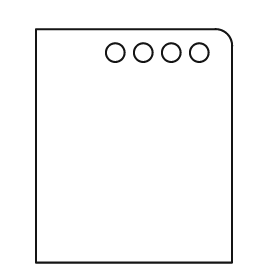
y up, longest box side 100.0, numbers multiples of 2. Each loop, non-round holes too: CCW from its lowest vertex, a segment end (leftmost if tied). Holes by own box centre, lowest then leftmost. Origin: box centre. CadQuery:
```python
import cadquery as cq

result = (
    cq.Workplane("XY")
    .moveTo(-42.0, -50.0)
    .lineTo(42.0, -50.0)
    .lineTo(42.0, 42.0)
    .threePointArc((40.0, 48.0), (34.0, 50.0))
    .lineTo(-42.0, 50.0)
    .close()
    .moveTo(-8.0, 40.0)
    .circle(4.0)
    .moveTo(4.0, 40.0)
    .circle(4.0)
    .moveTo(16.0, 40.0)
    .circle(4.0)
    .moveTo(28.0, 40.0)
    .circle(4.0)
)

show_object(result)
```